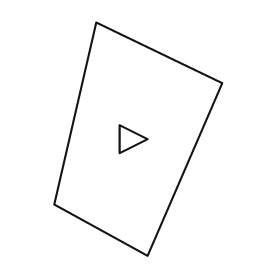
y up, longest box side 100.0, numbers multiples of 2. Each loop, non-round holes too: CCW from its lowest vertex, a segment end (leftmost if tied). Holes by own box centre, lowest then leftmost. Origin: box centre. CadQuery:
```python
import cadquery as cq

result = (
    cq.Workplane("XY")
    .moveTo(4.0, -50.0)
    .lineTo(36.0, 24.0)
    .lineTo(-18.0, 50.0)
    .lineTo(-36.0, -28.0)
    .close()
    .moveTo(-8.0, -6.0)
    .lineTo(4.0, 0.0)
    .lineTo(-8.0, 6.0)
    .close()
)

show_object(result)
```